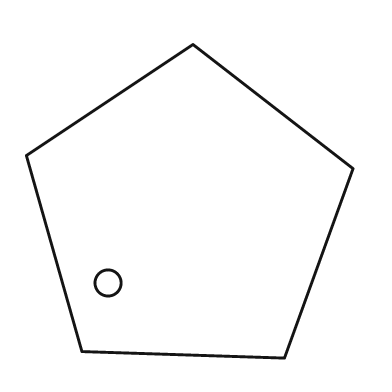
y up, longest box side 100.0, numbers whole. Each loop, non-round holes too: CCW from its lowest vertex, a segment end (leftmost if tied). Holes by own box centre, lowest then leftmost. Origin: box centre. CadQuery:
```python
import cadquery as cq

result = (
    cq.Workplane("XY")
    .moveTo(29.0, -48.0)
    .lineTo(50.0, 10.0)
    .lineTo(1.0, 48.0)
    .lineTo(-50.0, 14.0)
    .lineTo(-33.0, -46.0)
    .close()
    .moveTo(-25.0, -25.0)
    .circle(4.0)
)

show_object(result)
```